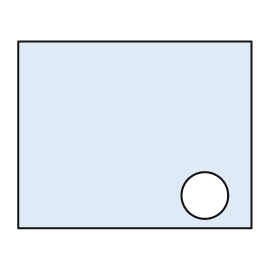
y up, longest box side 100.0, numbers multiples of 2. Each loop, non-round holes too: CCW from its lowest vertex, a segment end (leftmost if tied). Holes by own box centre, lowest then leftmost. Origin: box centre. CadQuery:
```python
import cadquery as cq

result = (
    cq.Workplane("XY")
    .moveTo(-50.0, -40.0)
    .lineTo(50.0, -40.0)
    .lineTo(50.0, 40.0)
    .lineTo(-50.0, 40.0)
    .close()
    .moveTo(30.0, -26.0)
    .circle(10.0)
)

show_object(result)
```